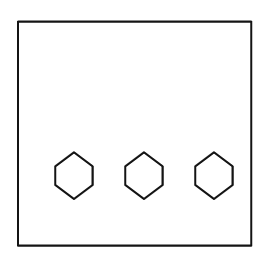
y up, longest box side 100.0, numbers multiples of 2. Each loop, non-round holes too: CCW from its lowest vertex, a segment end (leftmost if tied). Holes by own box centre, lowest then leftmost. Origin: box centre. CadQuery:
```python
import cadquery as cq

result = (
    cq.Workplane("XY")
    .moveTo(-50.0, -48.0)
    .lineTo(50.0, -48.0)
    .lineTo(50.0, 48.0)
    .lineTo(-50.0, 48.0)
    .close()
    .moveTo(-26.0, -28.0)
    .lineTo(-18.0, -22.0)
    .lineTo(-18.0, -14.0)
    .lineTo(-26.0, -8.0)
    .lineTo(-34.0, -14.0)
    .lineTo(-34.0, -22.0)
    .close()
    .moveTo(4.0, -28.0)
    .lineTo(12.0, -22.0)
    .lineTo(12.0, -14.0)
    .lineTo(4.0, -8.0)
    .lineTo(-4.0, -14.0)
    .lineTo(-4.0, -22.0)
    .close()
    .moveTo(34.0, -28.0)
    .lineTo(42.0, -22.0)
    .lineTo(42.0, -14.0)
    .lineTo(34.0, -8.0)
    .lineTo(26.0, -14.0)
    .lineTo(26.0, -22.0)
    .close()
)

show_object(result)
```